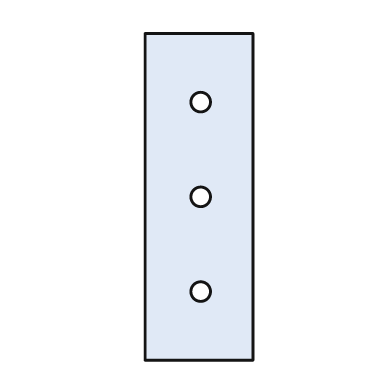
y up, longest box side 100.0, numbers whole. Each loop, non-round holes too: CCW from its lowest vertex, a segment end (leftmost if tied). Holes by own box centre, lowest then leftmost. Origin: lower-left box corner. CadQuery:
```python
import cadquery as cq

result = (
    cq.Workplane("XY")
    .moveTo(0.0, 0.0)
    .lineTo(33.0, 0.0)
    .lineTo(33.0, 100.0)
    .lineTo(0.0, 100.0)
    .close()
    .moveTo(17.0, 21.0)
    .circle(3.0)
    .moveTo(17.0, 50.0)
    .circle(3.0)
    .moveTo(17.0, 79.0)
    .circle(3.0)
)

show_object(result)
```